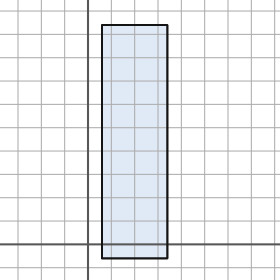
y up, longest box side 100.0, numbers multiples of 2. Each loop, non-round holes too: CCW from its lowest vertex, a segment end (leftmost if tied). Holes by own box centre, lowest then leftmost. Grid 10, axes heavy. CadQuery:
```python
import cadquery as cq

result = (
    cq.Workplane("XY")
    .moveTo(6.0, -6.0)
    .lineTo(34.0, -6.0)
    .lineTo(34.0, 94.0)
    .lineTo(6.0, 94.0)
    .close()
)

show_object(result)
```